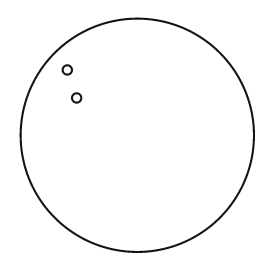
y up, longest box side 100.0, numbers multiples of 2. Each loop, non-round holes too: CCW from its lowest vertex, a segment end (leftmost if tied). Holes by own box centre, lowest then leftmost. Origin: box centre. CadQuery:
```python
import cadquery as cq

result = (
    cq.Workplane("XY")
    .moveTo(0.0, 0.0)
    .circle(50.0)
    .moveTo(-26.0, 16.0)
    .circle(2.0)
    .moveTo(-30.0, 28.0)
    .circle(2.0)
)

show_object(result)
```